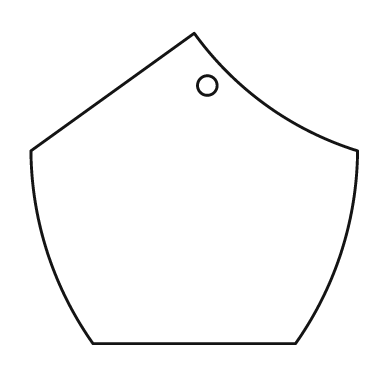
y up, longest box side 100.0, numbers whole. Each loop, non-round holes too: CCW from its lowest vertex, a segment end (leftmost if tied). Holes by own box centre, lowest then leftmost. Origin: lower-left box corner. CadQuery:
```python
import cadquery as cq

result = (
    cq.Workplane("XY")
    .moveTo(19.0, 0.0)
    .lineTo(81.0, 0.0)
    .threePointArc((95.0, 28.0), (100.0, 59.0))
    .threePointArc((72.0, 73.0), (50.0, 95.0))
    .lineTo(0.0, 59.0)
    .threePointArc((5.0, 28.0), (19.0, 0.0))
    .close()
    .moveTo(54.0, 79.0)
    .circle(3.0)
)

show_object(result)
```